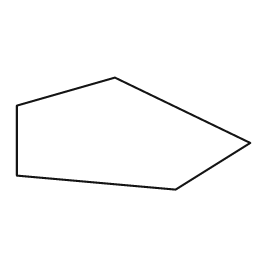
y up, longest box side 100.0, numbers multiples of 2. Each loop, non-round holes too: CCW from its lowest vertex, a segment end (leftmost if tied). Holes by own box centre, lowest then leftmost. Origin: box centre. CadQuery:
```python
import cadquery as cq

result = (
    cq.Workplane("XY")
    .moveTo(18.0, -24.0)
    .lineTo(50.0, -4.0)
    .lineTo(-8.0, 24.0)
    .lineTo(-50.0, 12.0)
    .lineTo(-50.0, -18.0)
    .close()
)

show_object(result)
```